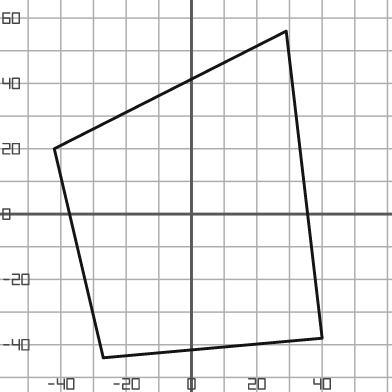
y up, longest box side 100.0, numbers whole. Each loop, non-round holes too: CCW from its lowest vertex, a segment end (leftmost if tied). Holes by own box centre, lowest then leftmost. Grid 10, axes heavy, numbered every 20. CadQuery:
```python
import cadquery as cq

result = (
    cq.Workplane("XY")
    .moveTo(-27.0, -44.0)
    .lineTo(40.0, -38.0)
    .lineTo(29.0, 56.0)
    .lineTo(-42.0, 20.0)
    .close()
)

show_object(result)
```